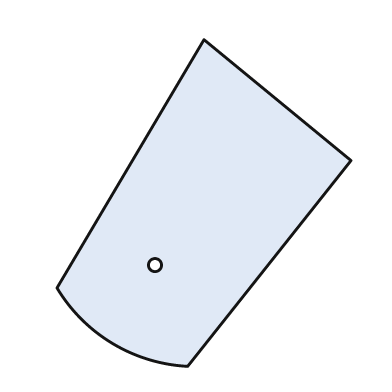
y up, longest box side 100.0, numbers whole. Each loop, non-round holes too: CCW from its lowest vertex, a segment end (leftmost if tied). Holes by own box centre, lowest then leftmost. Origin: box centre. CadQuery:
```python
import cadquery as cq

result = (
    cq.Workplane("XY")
    .moveTo(-5.0, -50.0)
    .lineTo(45.0, 13.0)
    .lineTo(0.0, 50.0)
    .lineTo(-45.0, -26.0)
    .threePointArc((-28.0, -43.0), (-5.0, -50.0))
    .close()
    .moveTo(-15.0, -19.0)
    .circle(2.0)
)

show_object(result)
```